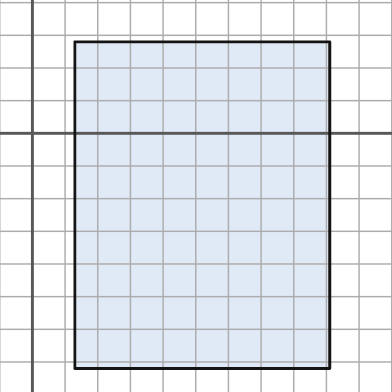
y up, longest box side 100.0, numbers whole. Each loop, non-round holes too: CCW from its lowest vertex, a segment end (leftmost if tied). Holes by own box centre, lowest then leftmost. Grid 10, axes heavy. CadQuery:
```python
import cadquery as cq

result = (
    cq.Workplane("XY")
    .moveTo(13.0, -72.0)
    .lineTo(91.0, -72.0)
    .lineTo(91.0, 28.0)
    .lineTo(13.0, 28.0)
    .close()
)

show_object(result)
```